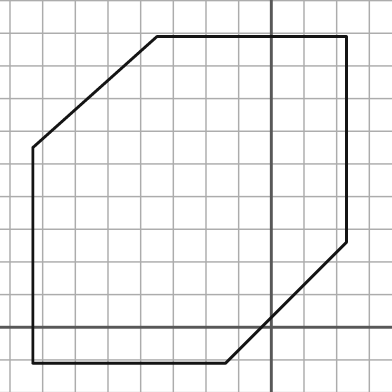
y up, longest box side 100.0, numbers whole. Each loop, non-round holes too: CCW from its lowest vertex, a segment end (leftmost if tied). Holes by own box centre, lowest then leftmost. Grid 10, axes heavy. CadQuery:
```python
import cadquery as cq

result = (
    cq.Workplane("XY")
    .moveTo(-73.0, -11.0)
    .lineTo(-14.0, -11.0)
    .lineTo(23.0, 26.0)
    .lineTo(23.0, 89.0)
    .lineTo(-35.0, 89.0)
    .lineTo(-73.0, 55.0)
    .close()
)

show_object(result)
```